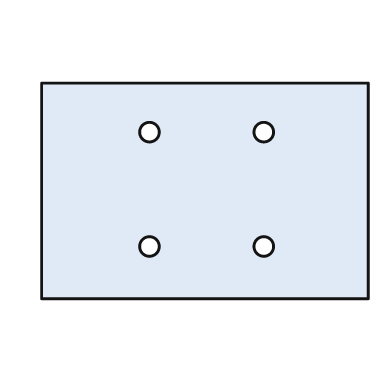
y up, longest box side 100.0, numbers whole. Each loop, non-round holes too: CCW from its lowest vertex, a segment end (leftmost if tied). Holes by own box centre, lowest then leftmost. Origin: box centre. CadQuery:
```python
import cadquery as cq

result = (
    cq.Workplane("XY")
    .moveTo(-50.0, -33.0)
    .lineTo(50.0, -33.0)
    .lineTo(50.0, 33.0)
    .lineTo(-50.0, 33.0)
    .close()
    .moveTo(-17.0, -17.0)
    .circle(3.0)
    .moveTo(18.0, -17.0)
    .circle(3.0)
    .moveTo(-17.0, 18.0)
    .circle(3.0)
    .moveTo(18.0, 18.0)
    .circle(3.0)
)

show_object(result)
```